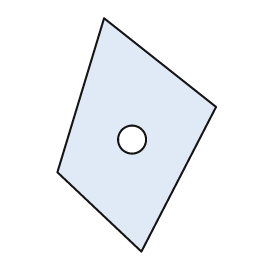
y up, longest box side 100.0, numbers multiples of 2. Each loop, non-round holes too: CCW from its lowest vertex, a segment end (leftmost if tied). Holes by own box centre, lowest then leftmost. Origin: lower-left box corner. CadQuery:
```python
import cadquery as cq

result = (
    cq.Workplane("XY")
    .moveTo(36.0, 0.0)
    .lineTo(68.0, 62.0)
    .lineTo(20.0, 100.0)
    .lineTo(0.0, 34.0)
    .close()
    .moveTo(32.0, 48.0)
    .circle(6.0)
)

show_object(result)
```